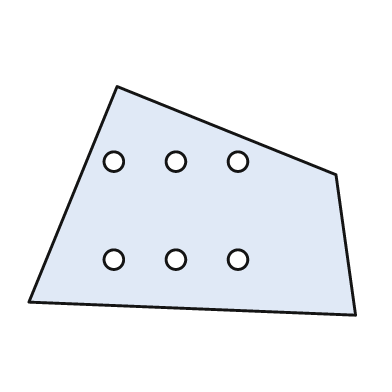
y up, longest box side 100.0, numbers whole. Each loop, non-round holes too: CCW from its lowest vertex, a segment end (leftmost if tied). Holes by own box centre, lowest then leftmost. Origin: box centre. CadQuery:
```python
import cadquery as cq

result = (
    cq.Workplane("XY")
    .moveTo(50.0, -35.0)
    .lineTo(44.0, 8.0)
    .lineTo(-23.0, 35.0)
    .lineTo(-50.0, -31.0)
    .close()
    .moveTo(-24.0, -18.0)
    .circle(3.0)
    .moveTo(-5.0, -18.0)
    .circle(3.0)
    .moveTo(14.0, -18.0)
    .circle(3.0)
    .moveTo(-24.0, 12.0)
    .circle(3.0)
    .moveTo(-5.0, 12.0)
    .circle(3.0)
    .moveTo(14.0, 12.0)
    .circle(3.0)
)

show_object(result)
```